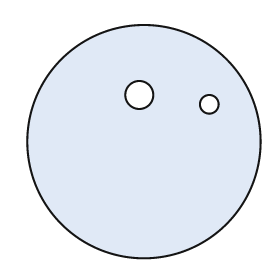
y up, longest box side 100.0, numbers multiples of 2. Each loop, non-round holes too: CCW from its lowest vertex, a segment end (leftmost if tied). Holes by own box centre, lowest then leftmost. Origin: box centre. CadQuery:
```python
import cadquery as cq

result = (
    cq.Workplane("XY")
    .moveTo(0.0, 0.0)
    .circle(50.0)
    .moveTo(28.0, 16.0)
    .circle(4.0)
    .moveTo(-2.0, 20.0)
    .circle(6.0)
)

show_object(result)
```